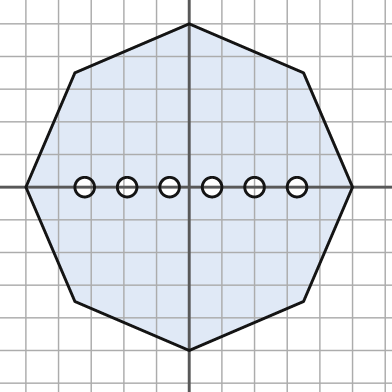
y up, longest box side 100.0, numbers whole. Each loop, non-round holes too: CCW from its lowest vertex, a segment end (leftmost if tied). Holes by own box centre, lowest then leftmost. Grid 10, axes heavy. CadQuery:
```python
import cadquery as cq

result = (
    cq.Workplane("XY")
    .moveTo(0.0, -50.0)
    .lineTo(35.0, -35.0)
    .lineTo(50.0, 0.0)
    .lineTo(35.0, 35.0)
    .lineTo(0.0, 50.0)
    .lineTo(-35.0, 35.0)
    .lineTo(-50.0, 0.0)
    .lineTo(-35.0, -35.0)
    .close()
    .moveTo(-32.0, 0.0)
    .circle(3.0)
    .moveTo(-19.0, 0.0)
    .circle(3.0)
    .moveTo(-6.0, 0.0)
    .circle(3.0)
    .moveTo(7.0, 0.0)
    .circle(3.0)
    .moveTo(20.0, 0.0)
    .circle(3.0)
    .moveTo(33.0, 0.0)
    .circle(3.0)
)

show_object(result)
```